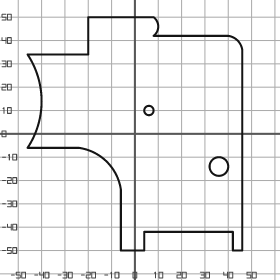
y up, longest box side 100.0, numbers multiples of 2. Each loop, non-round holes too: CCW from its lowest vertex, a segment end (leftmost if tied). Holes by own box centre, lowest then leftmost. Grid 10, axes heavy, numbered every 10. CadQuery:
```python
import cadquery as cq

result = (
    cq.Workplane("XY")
    .moveTo(-6.0, -50.0)
    .lineTo(4.0, -50.0)
    .lineTo(4.0, -42.0)
    .lineTo(42.0, -42.0)
    .lineTo(42.0, -50.0)
    .lineTo(46.0, -50.0)
    .lineTo(46.0, 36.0)
    .threePointArc((44.0, 40.0), (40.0, 42.0))
    .lineTo(8.0, 42.0)
    .threePointArc((10.0, 46.0), (8.0, 50.0))
    .lineTo(-20.0, 50.0)
    .lineTo(-20.0, 34.0)
    .lineTo(-46.0, 34.0)
    .threePointArc((-40.0, 14.0), (-46.0, -6.0))
    .lineTo(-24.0, -6.0)
    .threePointArc((-12.0, -12.0), (-6.0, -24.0))
    .close()
    .moveTo(36.0, -14.0)
    .circle(4.0)
    .moveTo(6.0, 10.0)
    .circle(2.0)
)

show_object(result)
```